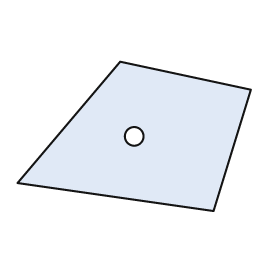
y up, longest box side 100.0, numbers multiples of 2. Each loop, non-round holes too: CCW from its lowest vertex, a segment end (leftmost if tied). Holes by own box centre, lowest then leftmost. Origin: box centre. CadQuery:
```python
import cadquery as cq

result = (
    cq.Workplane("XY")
    .moveTo(34.0, -32.0)
    .lineTo(50.0, 20.0)
    .lineTo(-6.0, 32.0)
    .lineTo(-50.0, -20.0)
    .close()
    .moveTo(0.0, 0.0)
    .circle(4.0)
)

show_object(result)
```